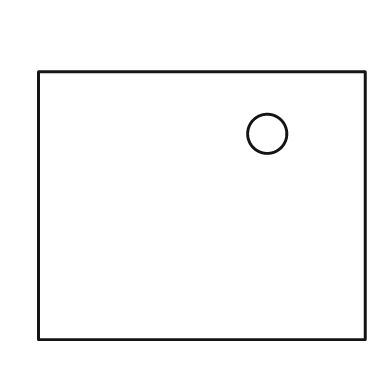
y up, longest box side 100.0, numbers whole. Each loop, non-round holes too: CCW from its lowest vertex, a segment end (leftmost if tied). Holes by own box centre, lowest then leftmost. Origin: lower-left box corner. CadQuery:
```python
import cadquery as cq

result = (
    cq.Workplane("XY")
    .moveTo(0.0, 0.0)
    .lineTo(100.0, 0.0)
    .lineTo(100.0, 82.0)
    .lineTo(0.0, 82.0)
    .close()
    .moveTo(70.0, 63.0)
    .circle(6.0)
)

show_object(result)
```